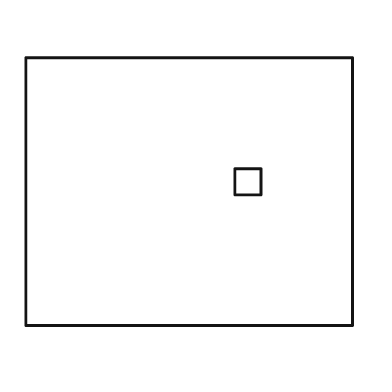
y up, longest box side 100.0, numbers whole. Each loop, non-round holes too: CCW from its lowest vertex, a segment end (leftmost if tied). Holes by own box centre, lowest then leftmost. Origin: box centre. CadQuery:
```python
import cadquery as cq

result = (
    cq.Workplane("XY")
    .moveTo(-50.0, -41.0)
    .lineTo(50.0, -41.0)
    .lineTo(50.0, 41.0)
    .lineTo(-50.0, 41.0)
    .close()
    .moveTo(14.0, -1.0)
    .lineTo(22.0, -1.0)
    .lineTo(22.0, 7.0)
    .lineTo(14.0, 7.0)
    .close()
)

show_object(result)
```